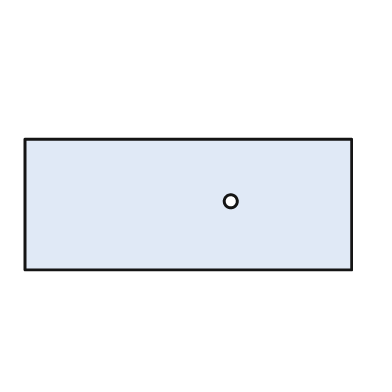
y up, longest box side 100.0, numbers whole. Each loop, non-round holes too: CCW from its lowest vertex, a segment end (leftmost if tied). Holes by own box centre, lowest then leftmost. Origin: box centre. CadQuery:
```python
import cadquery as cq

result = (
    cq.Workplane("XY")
    .moveTo(-50.0, -20.0)
    .lineTo(50.0, -20.0)
    .lineTo(50.0, 20.0)
    .lineTo(-50.0, 20.0)
    .close()
    .moveTo(13.0, 1.0)
    .circle(2.0)
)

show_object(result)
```